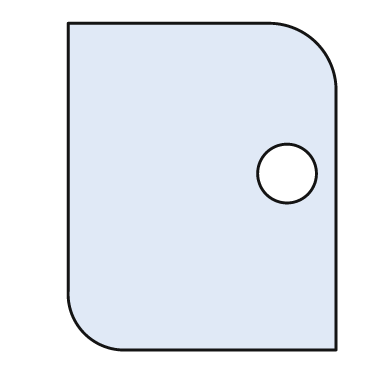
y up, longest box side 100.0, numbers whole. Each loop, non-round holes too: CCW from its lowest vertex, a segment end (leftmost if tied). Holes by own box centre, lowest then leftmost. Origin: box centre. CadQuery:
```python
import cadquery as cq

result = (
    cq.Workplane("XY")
    .moveTo(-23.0, -50.0)
    .lineTo(41.0, -50.0)
    .lineTo(41.0, 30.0)
    .threePointArc((35.0, 44.0), (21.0, 50.0))
    .lineTo(-41.0, 50.0)
    .lineTo(-41.0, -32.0)
    .threePointArc((-36.0, -45.0), (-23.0, -50.0))
    .close()
    .moveTo(26.0, 4.0)
    .circle(9.0)
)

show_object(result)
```